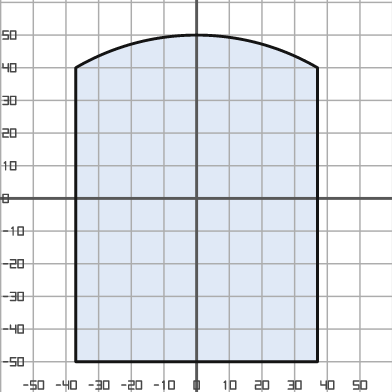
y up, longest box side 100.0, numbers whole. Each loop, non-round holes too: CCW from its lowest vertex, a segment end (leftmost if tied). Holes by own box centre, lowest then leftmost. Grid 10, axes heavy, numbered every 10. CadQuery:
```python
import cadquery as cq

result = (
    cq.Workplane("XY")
    .moveTo(-37.0, -50.0)
    .lineTo(37.0, -50.0)
    .lineTo(37.0, 40.0)
    .threePointArc((0.0, 50.0), (-37.0, 40.0))
    .close()
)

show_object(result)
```